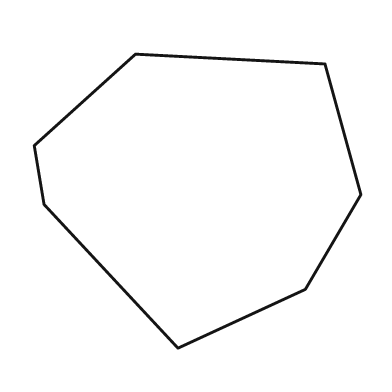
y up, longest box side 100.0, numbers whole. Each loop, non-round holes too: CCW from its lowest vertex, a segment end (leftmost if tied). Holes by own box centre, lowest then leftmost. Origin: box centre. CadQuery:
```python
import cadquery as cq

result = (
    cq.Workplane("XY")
    .moveTo(-6.0, -45.0)
    .lineTo(33.0, -27.0)
    .lineTo(50.0, 2.0)
    .lineTo(39.0, 42.0)
    .lineTo(-19.0, 45.0)
    .lineTo(-50.0, 17.0)
    .lineTo(-47.0, -1.0)
    .close()
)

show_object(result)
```